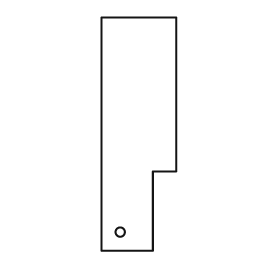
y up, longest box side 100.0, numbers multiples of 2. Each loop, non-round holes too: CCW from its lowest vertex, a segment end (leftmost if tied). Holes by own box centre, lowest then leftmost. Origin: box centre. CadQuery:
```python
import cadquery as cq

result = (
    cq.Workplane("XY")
    .moveTo(-16.0, -50.0)
    .lineTo(6.0, -50.0)
    .lineTo(6.0, -16.0)
    .lineTo(16.0, -16.0)
    .lineTo(16.0, 50.0)
    .lineTo(-16.0, 50.0)
    .close()
    .moveTo(-8.0, -42.0)
    .circle(2.0)
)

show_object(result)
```